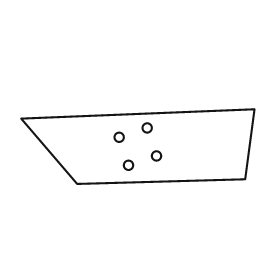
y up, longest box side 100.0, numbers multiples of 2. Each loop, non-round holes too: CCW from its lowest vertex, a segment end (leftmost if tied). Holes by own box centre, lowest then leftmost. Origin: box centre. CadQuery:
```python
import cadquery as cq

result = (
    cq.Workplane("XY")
    .moveTo(-26.0, -16.0)
    .lineTo(46.0, -14.0)
    .lineTo(50.0, 16.0)
    .lineTo(-50.0, 12.0)
    .close()
    .moveTo(-4.0, -8.0)
    .circle(2.0)
    .moveTo(8.0, -4.0)
    .circle(2.0)
    .moveTo(-8.0, 4.0)
    .circle(2.0)
    .moveTo(4.0, 8.0)
    .circle(2.0)
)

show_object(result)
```